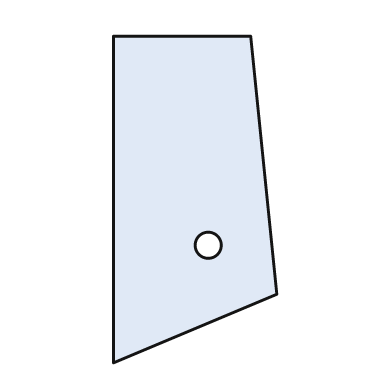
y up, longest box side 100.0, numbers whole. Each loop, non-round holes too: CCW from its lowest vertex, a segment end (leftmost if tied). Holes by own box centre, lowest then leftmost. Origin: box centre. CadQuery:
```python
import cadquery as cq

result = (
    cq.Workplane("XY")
    .moveTo(-25.0, -50.0)
    .lineTo(25.0, -29.0)
    .lineTo(17.0, 50.0)
    .lineTo(-25.0, 50.0)
    .close()
    .moveTo(4.0, -14.0)
    .circle(4.0)
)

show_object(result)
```